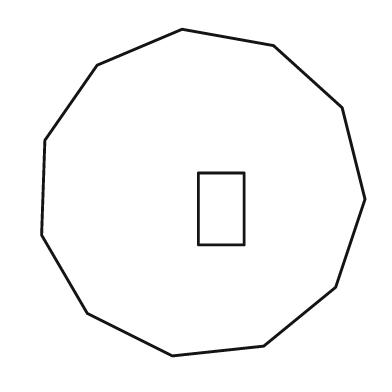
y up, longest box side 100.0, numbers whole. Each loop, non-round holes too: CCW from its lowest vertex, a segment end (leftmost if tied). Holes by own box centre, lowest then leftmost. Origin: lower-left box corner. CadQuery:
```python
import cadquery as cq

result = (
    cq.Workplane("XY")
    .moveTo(40.0, 0.0)
    .lineTo(68.0, 3.0)
    .lineTo(90.0, 21.0)
    .lineTo(99.0, 48.0)
    .lineTo(92.0, 76.0)
    .lineTo(71.0, 95.0)
    .lineTo(43.0, 100.0)
    .lineTo(17.0, 89.0)
    .lineTo(1.0, 66.0)
    .lineTo(0.0, 37.0)
    .lineTo(14.0, 13.0)
    .close()
    .moveTo(48.0, 34.0)
    .lineTo(62.0, 34.0)
    .lineTo(62.0, 56.0)
    .lineTo(48.0, 56.0)
    .close()
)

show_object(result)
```